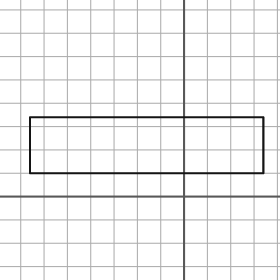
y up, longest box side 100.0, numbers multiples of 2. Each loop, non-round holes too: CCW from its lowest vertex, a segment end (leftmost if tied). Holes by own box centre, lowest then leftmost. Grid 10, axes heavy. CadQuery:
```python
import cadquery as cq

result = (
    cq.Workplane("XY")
    .moveTo(-66.0, 10.0)
    .lineTo(34.0, 10.0)
    .lineTo(34.0, 34.0)
    .lineTo(-66.0, 34.0)
    .close()
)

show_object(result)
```